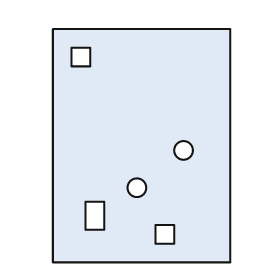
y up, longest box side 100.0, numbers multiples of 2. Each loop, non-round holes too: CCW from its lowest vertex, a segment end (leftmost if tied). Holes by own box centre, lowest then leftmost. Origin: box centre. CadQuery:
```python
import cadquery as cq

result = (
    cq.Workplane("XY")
    .moveTo(-38.0, -50.0)
    .lineTo(38.0, -50.0)
    .lineTo(38.0, 50.0)
    .lineTo(-38.0, 50.0)
    .close()
    .moveTo(6.0, -42.0)
    .lineTo(14.0, -42.0)
    .lineTo(14.0, -34.0)
    .lineTo(6.0, -34.0)
    .close()
    .moveTo(-24.0, -36.0)
    .lineTo(-16.0, -36.0)
    .lineTo(-16.0, -24.0)
    .lineTo(-24.0, -24.0)
    .close()
    .moveTo(-2.0, -18.0)
    .circle(4.0)
    .moveTo(18.0, -2.0)
    .circle(4.0)
    .moveTo(-30.0, 34.0)
    .lineTo(-22.0, 34.0)
    .lineTo(-22.0, 42.0)
    .lineTo(-30.0, 42.0)
    .close()
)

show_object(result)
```